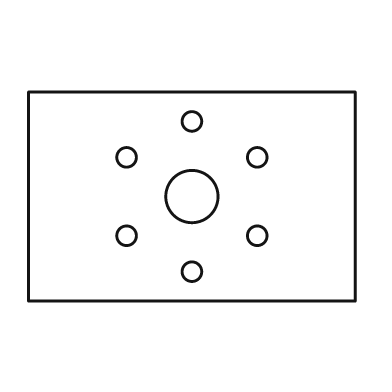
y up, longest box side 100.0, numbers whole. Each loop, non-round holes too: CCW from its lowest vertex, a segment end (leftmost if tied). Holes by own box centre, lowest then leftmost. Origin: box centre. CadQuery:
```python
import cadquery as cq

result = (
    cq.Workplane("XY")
    .moveTo(-50.0, -32.0)
    .lineTo(50.0, -32.0)
    .lineTo(50.0, 32.0)
    .lineTo(-50.0, 32.0)
    .close()
    .moveTo(0.0, -23.0)
    .circle(3.0)
    .moveTo(-20.0, -12.0)
    .circle(3.0)
    .moveTo(20.0, -12.0)
    .circle(3.0)
    .moveTo(0.0, 0.0)
    .circle(8.0)
    .moveTo(-20.0, 12.0)
    .circle(3.0)
    .moveTo(20.0, 12.0)
    .circle(3.0)
    .moveTo(0.0, 23.0)
    .circle(3.0)
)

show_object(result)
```